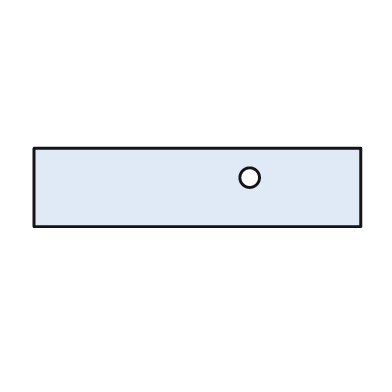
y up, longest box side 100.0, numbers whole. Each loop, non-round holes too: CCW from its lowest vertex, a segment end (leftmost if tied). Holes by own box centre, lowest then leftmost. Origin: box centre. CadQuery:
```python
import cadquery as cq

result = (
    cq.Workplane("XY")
    .moveTo(-50.0, -12.0)
    .lineTo(50.0, -12.0)
    .lineTo(50.0, 12.0)
    .lineTo(-50.0, 12.0)
    .close()
    .moveTo(16.0, 3.0)
    .circle(3.0)
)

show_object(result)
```